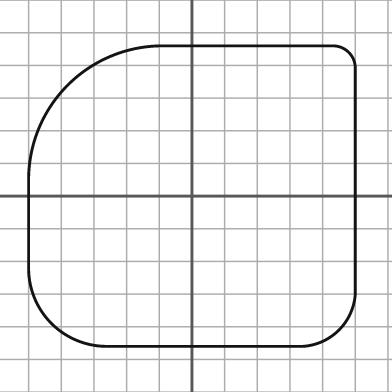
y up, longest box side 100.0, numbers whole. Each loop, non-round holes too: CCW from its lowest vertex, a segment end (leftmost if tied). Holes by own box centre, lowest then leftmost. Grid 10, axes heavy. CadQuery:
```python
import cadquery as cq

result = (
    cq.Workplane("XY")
    .moveTo(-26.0, -46.0)
    .lineTo(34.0, -46.0)
    .threePointArc((45.0, -41.0), (50.0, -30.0))
    .lineTo(50.0, 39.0)
    .threePointArc((48.0, 44.0), (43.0, 46.0))
    .lineTo(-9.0, 46.0)
    .threePointArc((-38.0, 34.0), (-50.0, 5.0))
    .lineTo(-50.0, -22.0)
    .threePointArc((-43.0, -39.0), (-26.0, -46.0))
    .close()
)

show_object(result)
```